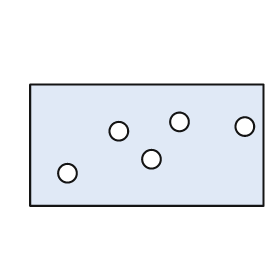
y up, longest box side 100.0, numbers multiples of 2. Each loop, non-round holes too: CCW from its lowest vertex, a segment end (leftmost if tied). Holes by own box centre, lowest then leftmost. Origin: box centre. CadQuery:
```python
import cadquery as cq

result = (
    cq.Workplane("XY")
    .moveTo(-50.0, -26.0)
    .lineTo(50.0, -26.0)
    .lineTo(50.0, 26.0)
    .lineTo(-50.0, 26.0)
    .close()
    .moveTo(-34.0, -12.0)
    .circle(4.0)
    .moveTo(2.0, -6.0)
    .circle(4.0)
    .moveTo(-12.0, 6.0)
    .circle(4.0)
    .moveTo(42.0, 8.0)
    .circle(4.0)
    .moveTo(14.0, 10.0)
    .circle(4.0)
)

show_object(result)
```